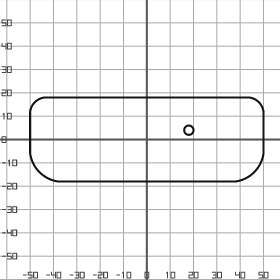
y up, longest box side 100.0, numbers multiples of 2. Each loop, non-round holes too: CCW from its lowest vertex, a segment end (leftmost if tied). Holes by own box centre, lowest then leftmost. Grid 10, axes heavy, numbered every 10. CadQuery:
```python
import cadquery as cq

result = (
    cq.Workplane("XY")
    .moveTo(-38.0, -18.0)
    .lineTo(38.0, -18.0)
    .threePointArc((46.0, -14.0), (50.0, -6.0))
    .lineTo(50.0, 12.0)
    .threePointArc((48.0, 16.0), (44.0, 18.0))
    .lineTo(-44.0, 18.0)
    .threePointArc((-48.0, 16.0), (-50.0, 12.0))
    .lineTo(-50.0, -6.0)
    .threePointArc((-46.0, -14.0), (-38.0, -18.0))
    .close()
    .moveTo(18.0, 4.0)
    .circle(2.0)
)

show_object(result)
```